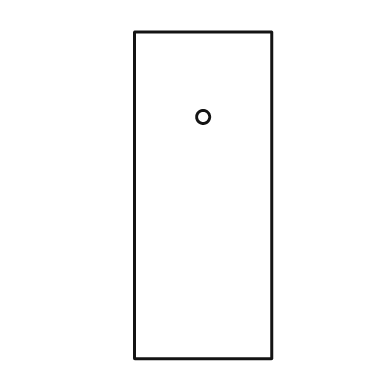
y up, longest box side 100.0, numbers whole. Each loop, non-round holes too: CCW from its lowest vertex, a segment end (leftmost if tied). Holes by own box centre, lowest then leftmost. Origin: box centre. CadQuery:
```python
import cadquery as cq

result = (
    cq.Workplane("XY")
    .moveTo(-21.0, -50.0)
    .lineTo(21.0, -50.0)
    .lineTo(21.0, 50.0)
    .lineTo(-21.0, 50.0)
    .close()
    .moveTo(0.0, 24.0)
    .circle(2.0)
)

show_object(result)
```